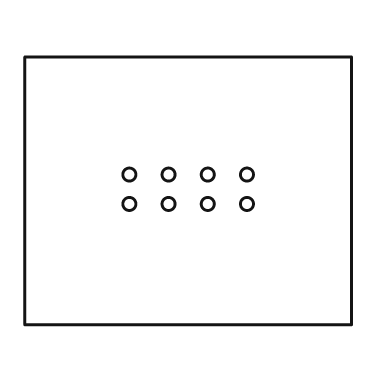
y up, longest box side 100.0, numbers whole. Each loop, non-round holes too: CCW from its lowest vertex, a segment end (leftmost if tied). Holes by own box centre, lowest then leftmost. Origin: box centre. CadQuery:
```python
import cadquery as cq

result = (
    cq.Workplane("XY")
    .moveTo(-50.0, -41.0)
    .lineTo(50.0, -41.0)
    .lineTo(50.0, 41.0)
    .lineTo(-50.0, 41.0)
    .close()
    .moveTo(-18.0, -4.0)
    .circle(2.0)
    .moveTo(-6.0, -4.0)
    .circle(2.0)
    .moveTo(6.0, -4.0)
    .circle(2.0)
    .moveTo(18.0, -4.0)
    .circle(2.0)
    .moveTo(-18.0, 5.0)
    .circle(2.0)
    .moveTo(-6.0, 5.0)
    .circle(2.0)
    .moveTo(6.0, 5.0)
    .circle(2.0)
    .moveTo(18.0, 5.0)
    .circle(2.0)
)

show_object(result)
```